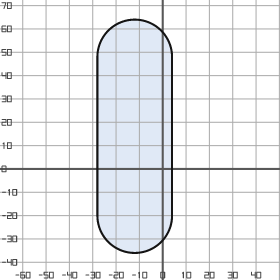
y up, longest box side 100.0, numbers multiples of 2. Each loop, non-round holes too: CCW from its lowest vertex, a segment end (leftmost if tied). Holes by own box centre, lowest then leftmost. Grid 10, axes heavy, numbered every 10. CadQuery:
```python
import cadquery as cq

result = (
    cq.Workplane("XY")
    .moveTo(-28.0, -20.0)
    .threePointArc((-12.0, -36.0), (4.0, -20.0))
    .lineTo(4.0, 48.0)
    .threePointArc((-12.0, 64.0), (-28.0, 48.0))
    .close()
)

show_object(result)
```